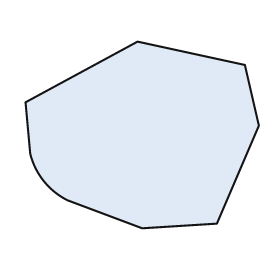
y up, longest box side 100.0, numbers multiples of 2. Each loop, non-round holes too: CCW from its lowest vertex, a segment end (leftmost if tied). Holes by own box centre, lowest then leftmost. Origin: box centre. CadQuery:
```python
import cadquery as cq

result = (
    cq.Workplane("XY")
    .moveTo(0.0, -40.0)
    .lineTo(32.0, -38.0)
    .lineTo(50.0, 4.0)
    .lineTo(44.0, 30.0)
    .lineTo(-2.0, 40.0)
    .lineTo(-50.0, 14.0)
    .lineTo(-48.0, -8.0)
    .threePointArc((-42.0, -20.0), (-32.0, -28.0))
    .close()
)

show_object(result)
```